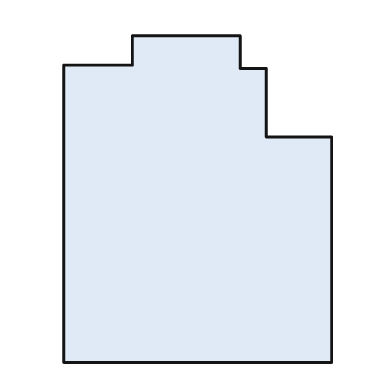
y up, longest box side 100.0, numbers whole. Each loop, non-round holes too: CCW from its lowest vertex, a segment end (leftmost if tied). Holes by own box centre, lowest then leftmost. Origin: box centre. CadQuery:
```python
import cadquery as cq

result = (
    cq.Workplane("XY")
    .moveTo(-41.0, -50.0)
    .lineTo(41.0, -50.0)
    .lineTo(41.0, 19.0)
    .lineTo(21.0, 19.0)
    .lineTo(21.0, 40.0)
    .lineTo(13.0, 40.0)
    .lineTo(13.0, 50.0)
    .lineTo(-20.0, 50.0)
    .lineTo(-20.0, 41.0)
    .lineTo(-41.0, 41.0)
    .close()
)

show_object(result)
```